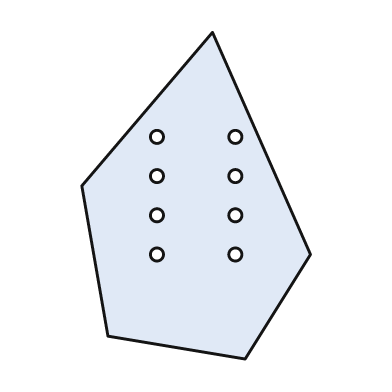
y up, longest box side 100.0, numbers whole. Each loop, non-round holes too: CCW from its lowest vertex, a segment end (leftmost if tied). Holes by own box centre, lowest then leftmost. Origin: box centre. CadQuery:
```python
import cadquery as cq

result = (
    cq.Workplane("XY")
    .moveTo(15.0, -50.0)
    .lineTo(35.0, -18.0)
    .lineTo(5.0, 50.0)
    .lineTo(-35.0, 3.0)
    .lineTo(-27.0, -43.0)
    .close()
    .moveTo(-12.0, -18.0)
    .circle(2.0)
    .moveTo(12.0, -18.0)
    .circle(2.0)
    .moveTo(-12.0, -6.0)
    .circle(2.0)
    .moveTo(12.0, -6.0)
    .circle(2.0)
    .moveTo(-12.0, 6.0)
    .circle(2.0)
    .moveTo(12.0, 6.0)
    .circle(2.0)
    .moveTo(-12.0, 18.0)
    .circle(2.0)
    .moveTo(12.0, 18.0)
    .circle(2.0)
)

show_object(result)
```